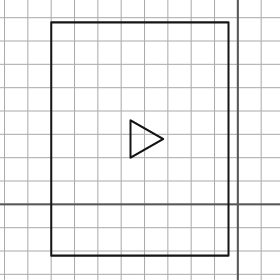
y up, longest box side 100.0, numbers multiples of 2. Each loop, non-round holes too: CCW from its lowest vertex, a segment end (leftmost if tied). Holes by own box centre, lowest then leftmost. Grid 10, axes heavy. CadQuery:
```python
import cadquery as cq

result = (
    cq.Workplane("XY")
    .moveTo(-80.0, -22.0)
    .lineTo(-4.0, -22.0)
    .lineTo(-4.0, 78.0)
    .lineTo(-80.0, 78.0)
    .close()
    .moveTo(-46.0, 20.0)
    .lineTo(-32.0, 28.0)
    .lineTo(-46.0, 36.0)
    .close()
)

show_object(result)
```